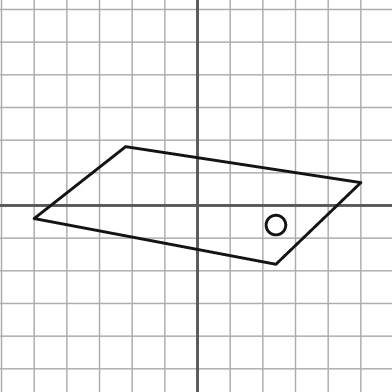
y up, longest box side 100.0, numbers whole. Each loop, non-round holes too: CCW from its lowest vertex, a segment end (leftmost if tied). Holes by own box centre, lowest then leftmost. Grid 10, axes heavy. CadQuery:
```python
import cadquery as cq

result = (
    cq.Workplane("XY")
    .moveTo(24.0, -18.0)
    .lineTo(50.0, 7.0)
    .lineTo(-22.0, 18.0)
    .lineTo(-50.0, -4.0)
    .close()
    .moveTo(24.0, -6.0)
    .circle(3.0)
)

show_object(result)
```